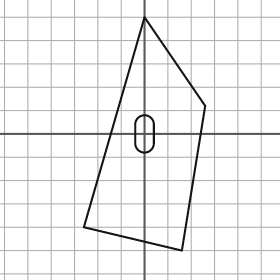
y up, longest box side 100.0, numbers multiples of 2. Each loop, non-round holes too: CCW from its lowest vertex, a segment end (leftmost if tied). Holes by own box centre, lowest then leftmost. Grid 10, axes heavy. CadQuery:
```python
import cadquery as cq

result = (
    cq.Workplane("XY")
    .moveTo(16.0, -50.0)
    .lineTo(26.0, 12.0)
    .lineTo(0.0, 50.0)
    .lineTo(-26.0, -40.0)
    .close()
    .moveTo(-4.0, -4.0)
    .threePointArc((0.0, -8.0), (4.0, -4.0))
    .lineTo(4.0, 4.0)
    .threePointArc((0.0, 8.0), (-4.0, 4.0))
    .close()
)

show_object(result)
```